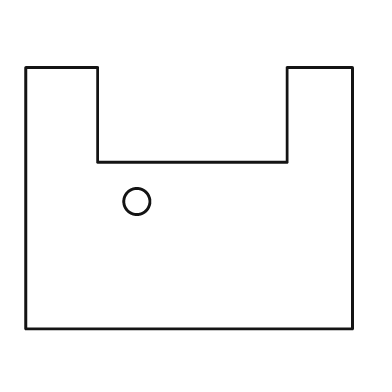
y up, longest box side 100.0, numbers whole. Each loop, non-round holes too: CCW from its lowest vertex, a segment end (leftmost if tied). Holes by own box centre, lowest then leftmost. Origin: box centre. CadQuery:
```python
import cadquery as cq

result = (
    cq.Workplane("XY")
    .moveTo(-50.0, -40.0)
    .lineTo(50.0, -40.0)
    .lineTo(50.0, 40.0)
    .lineTo(30.0, 40.0)
    .lineTo(30.0, 11.0)
    .lineTo(-28.0, 11.0)
    .lineTo(-28.0, 40.0)
    .lineTo(-50.0, 40.0)
    .close()
    .moveTo(-16.0, -1.0)
    .circle(4.0)
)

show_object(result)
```